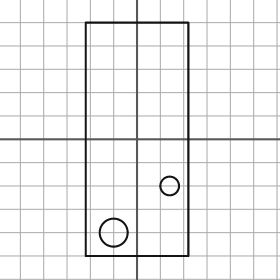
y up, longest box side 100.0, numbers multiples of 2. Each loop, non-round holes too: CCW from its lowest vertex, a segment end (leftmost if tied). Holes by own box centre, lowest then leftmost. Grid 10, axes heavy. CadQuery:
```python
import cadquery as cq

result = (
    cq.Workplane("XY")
    .moveTo(-22.0, -50.0)
    .lineTo(22.0, -50.0)
    .lineTo(22.0, 50.0)
    .lineTo(-22.0, 50.0)
    .close()
    .moveTo(-10.0, -40.0)
    .circle(6.0)
    .moveTo(14.0, -20.0)
    .circle(4.0)
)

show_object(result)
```